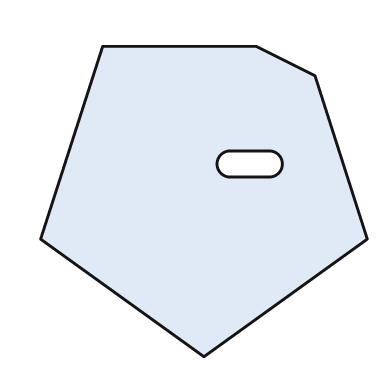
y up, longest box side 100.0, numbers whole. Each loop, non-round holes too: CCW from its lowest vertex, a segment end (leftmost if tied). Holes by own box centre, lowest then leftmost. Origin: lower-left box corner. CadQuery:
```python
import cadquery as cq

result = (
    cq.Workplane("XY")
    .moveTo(50.0, 0.0)
    .lineTo(100.0, 36.0)
    .lineTo(84.0, 86.0)
    .lineTo(66.0, 95.0)
    .lineTo(19.0, 95.0)
    .lineTo(0.0, 36.0)
    .close()
    .moveTo(58.0, 55.0)
    .lineTo(70.0, 55.0)
    .threePointArc((74.0, 59.0), (70.0, 63.0))
    .lineTo(58.0, 63.0)
    .threePointArc((54.0, 59.0), (58.0, 55.0))
    .close()
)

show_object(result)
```